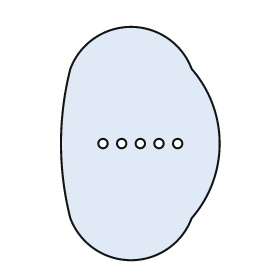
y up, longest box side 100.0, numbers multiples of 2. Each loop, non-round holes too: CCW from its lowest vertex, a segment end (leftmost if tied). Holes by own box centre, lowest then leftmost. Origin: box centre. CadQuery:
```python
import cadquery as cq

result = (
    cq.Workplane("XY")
    .moveTo(-30.0, -32.0)
    .threePointArc((-4.0, -50.0), (22.0, -32.0))
    .threePointArc((34.0, 0.0), (22.0, 32.0))
    .threePointArc((-4.0, 50.0), (-30.0, 32.0))
    .threePointArc((-34.0, 0.0), (-30.0, -32.0))
    .close()
    .moveTo(-16.0, 0.0)
    .circle(2.0)
    .moveTo(-8.0, 0.0)
    .circle(2.0)
    .moveTo(0.0, 0.0)
    .circle(2.0)
    .moveTo(8.0, 0.0)
    .circle(2.0)
    .moveTo(16.0, 0.0)
    .circle(2.0)
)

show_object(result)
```